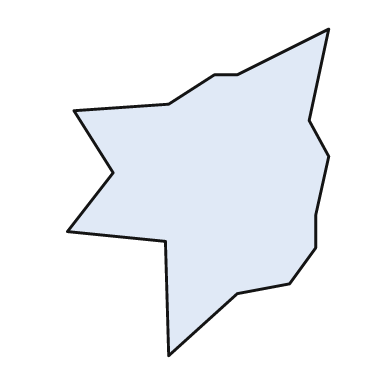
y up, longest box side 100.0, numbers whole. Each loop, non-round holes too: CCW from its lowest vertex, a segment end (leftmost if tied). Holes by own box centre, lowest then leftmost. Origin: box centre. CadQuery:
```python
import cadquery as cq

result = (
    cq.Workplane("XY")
    .moveTo(-9.0, -50.0)
    .lineTo(12.0, -31.0)
    .lineTo(28.0, -28.0)
    .lineTo(36.0, -17.0)
    .lineTo(36.0, -7.0)
    .lineTo(40.0, 11.0)
    .lineTo(34.0, 22.0)
    .lineTo(40.0, 50.0)
    .lineTo(12.0, 36.0)
    .lineTo(5.0, 36.0)
    .lineTo(-9.0, 27.0)
    .lineTo(-38.0, 25.0)
    .lineTo(-26.0, 6.0)
    .lineTo(-40.0, -12.0)
    .lineTo(-10.0, -15.0)
    .close()
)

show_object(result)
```